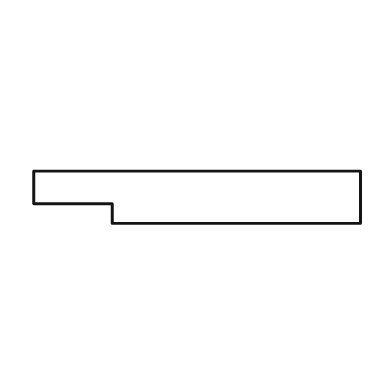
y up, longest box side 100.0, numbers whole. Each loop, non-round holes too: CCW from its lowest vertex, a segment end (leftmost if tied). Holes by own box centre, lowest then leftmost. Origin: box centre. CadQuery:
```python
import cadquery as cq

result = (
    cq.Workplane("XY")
    .moveTo(-26.0, -8.0)
    .lineTo(50.0, -8.0)
    .lineTo(50.0, 8.0)
    .lineTo(-50.0, 8.0)
    .lineTo(-50.0, -2.0)
    .lineTo(-26.0, -2.0)
    .close()
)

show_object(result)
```